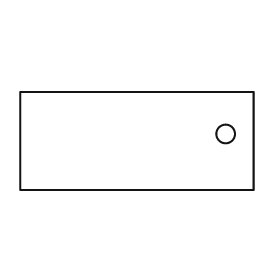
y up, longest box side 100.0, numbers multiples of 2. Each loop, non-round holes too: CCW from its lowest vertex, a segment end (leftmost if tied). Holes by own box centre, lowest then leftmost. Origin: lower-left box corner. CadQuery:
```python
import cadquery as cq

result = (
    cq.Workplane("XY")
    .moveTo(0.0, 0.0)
    .lineTo(100.0, 0.0)
    .lineTo(100.0, 42.0)
    .lineTo(0.0, 42.0)
    .close()
    .moveTo(88.0, 24.0)
    .circle(4.0)
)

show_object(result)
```